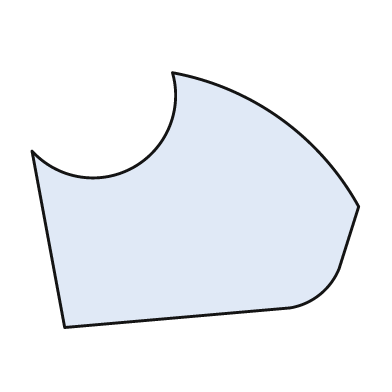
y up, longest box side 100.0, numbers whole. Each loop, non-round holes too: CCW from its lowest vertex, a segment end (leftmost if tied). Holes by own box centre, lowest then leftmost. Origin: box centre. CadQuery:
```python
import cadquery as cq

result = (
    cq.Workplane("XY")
    .moveTo(-40.0, -39.0)
    .lineTo(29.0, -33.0)
    .threePointArc((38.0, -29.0), (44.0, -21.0))
    .lineTo(50.0, -2.0)
    .threePointArc((26.0, 25.0), (-7.0, 39.0))
    .threePointArc((-19.0, 10.0), (-50.0, 15.0))
    .close()
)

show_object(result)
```